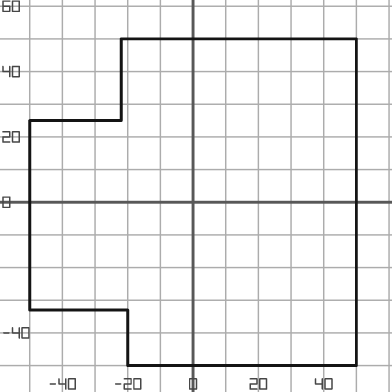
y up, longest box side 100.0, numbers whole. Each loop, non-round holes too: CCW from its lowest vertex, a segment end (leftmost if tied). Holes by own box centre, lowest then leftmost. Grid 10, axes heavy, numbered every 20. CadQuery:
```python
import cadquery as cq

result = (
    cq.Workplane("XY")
    .moveTo(-20.0, -50.0)
    .lineTo(50.0, -50.0)
    .lineTo(50.0, 50.0)
    .lineTo(-22.0, 50.0)
    .lineTo(-22.0, 25.0)
    .lineTo(-50.0, 25.0)
    .lineTo(-50.0, -33.0)
    .lineTo(-20.0, -33.0)
    .close()
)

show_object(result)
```